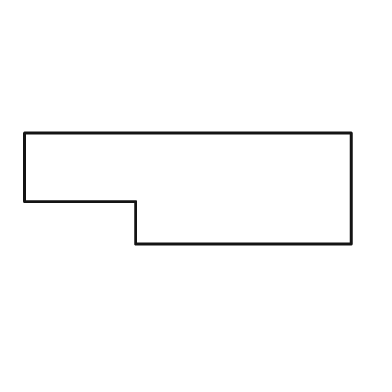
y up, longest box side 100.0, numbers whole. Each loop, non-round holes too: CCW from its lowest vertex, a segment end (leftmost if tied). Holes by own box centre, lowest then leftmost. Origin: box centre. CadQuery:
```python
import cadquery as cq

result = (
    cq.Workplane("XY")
    .moveTo(-16.0, -17.0)
    .lineTo(50.0, -17.0)
    .lineTo(50.0, 17.0)
    .lineTo(-50.0, 17.0)
    .lineTo(-50.0, -4.0)
    .lineTo(-16.0, -4.0)
    .close()
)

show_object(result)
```